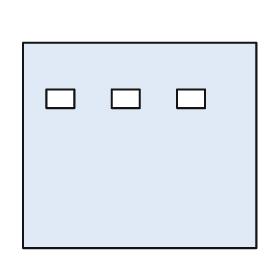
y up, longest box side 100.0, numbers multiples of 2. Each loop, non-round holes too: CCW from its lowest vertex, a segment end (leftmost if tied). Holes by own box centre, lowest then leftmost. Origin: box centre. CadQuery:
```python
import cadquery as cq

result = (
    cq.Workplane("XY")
    .moveTo(-50.0, -44.0)
    .lineTo(50.0, -44.0)
    .lineTo(50.0, 44.0)
    .lineTo(-50.0, 44.0)
    .close()
    .moveTo(-40.0, 16.0)
    .lineTo(-28.0, 16.0)
    .lineTo(-28.0, 24.0)
    .lineTo(-40.0, 24.0)
    .close()
    .moveTo(-12.0, 16.0)
    .lineTo(0.0, 16.0)
    .lineTo(0.0, 24.0)
    .lineTo(-12.0, 24.0)
    .close()
    .moveTo(16.0, 16.0)
    .lineTo(28.0, 16.0)
    .lineTo(28.0, 24.0)
    .lineTo(16.0, 24.0)
    .close()
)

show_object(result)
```